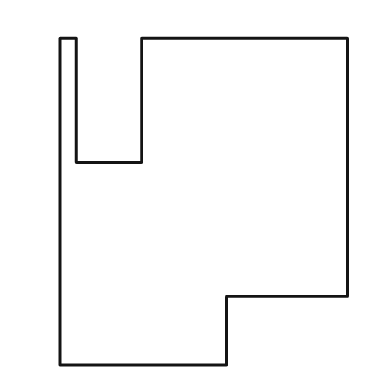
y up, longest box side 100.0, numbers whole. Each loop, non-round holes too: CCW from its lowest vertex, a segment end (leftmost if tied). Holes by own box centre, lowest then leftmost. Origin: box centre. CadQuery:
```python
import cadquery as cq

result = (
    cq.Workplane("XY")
    .moveTo(-44.0, -50.0)
    .lineTo(7.0, -50.0)
    .lineTo(7.0, -29.0)
    .lineTo(44.0, -29.0)
    .lineTo(44.0, 50.0)
    .lineTo(-19.0, 50.0)
    .lineTo(-19.0, 12.0)
    .lineTo(-39.0, 12.0)
    .lineTo(-39.0, 50.0)
    .lineTo(-44.0, 50.0)
    .close()
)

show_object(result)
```